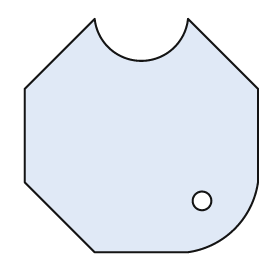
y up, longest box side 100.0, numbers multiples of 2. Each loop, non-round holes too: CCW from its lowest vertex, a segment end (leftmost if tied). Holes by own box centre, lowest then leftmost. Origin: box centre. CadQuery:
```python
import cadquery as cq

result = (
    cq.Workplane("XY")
    .moveTo(-20.0, -50.0)
    .lineTo(20.0, -50.0)
    .threePointArc((40.0, -40.0), (50.0, -20.0))
    .lineTo(50.0, 20.0)
    .lineTo(20.0, 50.0)
    .threePointArc((0.0, 32.0), (-20.0, 50.0))
    .lineTo(-50.0, 20.0)
    .lineTo(-50.0, -20.0)
    .close()
    .moveTo(26.0, -28.0)
    .circle(4.0)
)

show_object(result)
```